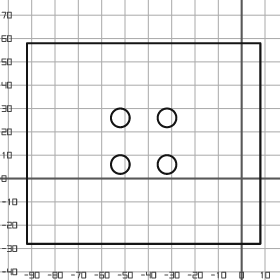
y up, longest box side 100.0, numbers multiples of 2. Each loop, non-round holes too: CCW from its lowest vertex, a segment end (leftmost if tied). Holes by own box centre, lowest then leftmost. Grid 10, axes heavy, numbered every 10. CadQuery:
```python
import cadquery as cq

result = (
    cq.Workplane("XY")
    .moveTo(-92.0, -28.0)
    .lineTo(8.0, -28.0)
    .lineTo(8.0, 58.0)
    .lineTo(-92.0, 58.0)
    .close()
    .moveTo(-52.0, 6.0)
    .circle(4.0)
    .moveTo(-32.0, 6.0)
    .circle(4.0)
    .moveTo(-52.0, 26.0)
    .circle(4.0)
    .moveTo(-32.0, 26.0)
    .circle(4.0)
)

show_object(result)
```